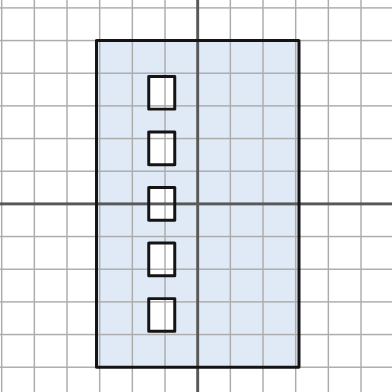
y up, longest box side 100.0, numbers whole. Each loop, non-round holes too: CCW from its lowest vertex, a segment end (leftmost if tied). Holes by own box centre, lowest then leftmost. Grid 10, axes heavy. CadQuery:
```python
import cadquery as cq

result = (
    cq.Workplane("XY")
    .moveTo(-31.0, -50.0)
    .lineTo(31.0, -50.0)
    .lineTo(31.0, 50.0)
    .lineTo(-31.0, 50.0)
    .close()
    .moveTo(-15.0, -39.0)
    .lineTo(-7.0, -39.0)
    .lineTo(-7.0, -29.0)
    .lineTo(-15.0, -29.0)
    .close()
    .moveTo(-15.0, -22.0)
    .lineTo(-7.0, -22.0)
    .lineTo(-7.0, -12.0)
    .lineTo(-15.0, -12.0)
    .close()
    .moveTo(-15.0, -5.0)
    .lineTo(-7.0, -5.0)
    .lineTo(-7.0, 5.0)
    .lineTo(-15.0, 5.0)
    .close()
    .moveTo(-15.0, 12.0)
    .lineTo(-7.0, 12.0)
    .lineTo(-7.0, 22.0)
    .lineTo(-15.0, 22.0)
    .close()
    .moveTo(-15.0, 29.0)
    .lineTo(-7.0, 29.0)
    .lineTo(-7.0, 39.0)
    .lineTo(-15.0, 39.0)
    .close()
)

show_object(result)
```